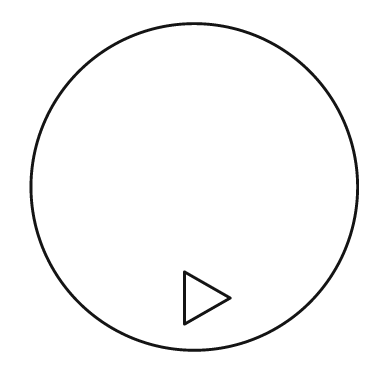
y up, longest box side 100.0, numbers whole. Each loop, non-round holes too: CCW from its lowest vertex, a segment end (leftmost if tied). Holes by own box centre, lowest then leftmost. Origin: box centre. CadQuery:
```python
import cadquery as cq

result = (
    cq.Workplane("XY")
    .moveTo(0.0, 0.0)
    .circle(50.0)
    .moveTo(-3.0, -42.0)
    .lineTo(11.0, -34.0)
    .lineTo(-3.0, -26.0)
    .close()
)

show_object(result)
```